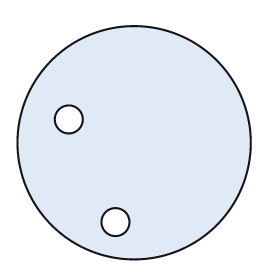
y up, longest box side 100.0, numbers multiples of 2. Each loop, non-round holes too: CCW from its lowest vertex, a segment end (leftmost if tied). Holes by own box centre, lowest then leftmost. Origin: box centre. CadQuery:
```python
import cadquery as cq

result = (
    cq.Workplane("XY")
    .moveTo(0.0, 0.0)
    .circle(50.0)
    .moveTo(-8.0, -34.0)
    .circle(6.0)
    .moveTo(-28.0, 10.0)
    .circle(6.0)
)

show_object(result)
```